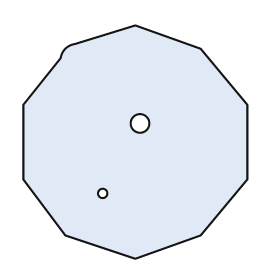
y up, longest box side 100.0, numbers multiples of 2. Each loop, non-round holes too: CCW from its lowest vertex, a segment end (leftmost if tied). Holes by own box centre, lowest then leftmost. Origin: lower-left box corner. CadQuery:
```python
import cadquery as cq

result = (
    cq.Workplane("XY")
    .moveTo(48.0, 0.0)
    .lineTo(76.0, 10.0)
    .lineTo(96.0, 34.0)
    .lineTo(96.0, 66.0)
    .lineTo(76.0, 90.0)
    .lineTo(48.0, 100.0)
    .lineTo(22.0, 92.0)
    .threePointArc((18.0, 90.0), (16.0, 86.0))
    .lineTo(0.0, 66.0)
    .lineTo(0.0, 34.0)
    .lineTo(18.0, 10.0)
    .close()
    .moveTo(34.0, 28.0)
    .circle(2.0)
    .moveTo(50.0, 58.0)
    .circle(4.0)
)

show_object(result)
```